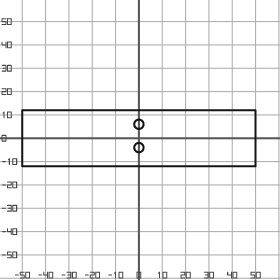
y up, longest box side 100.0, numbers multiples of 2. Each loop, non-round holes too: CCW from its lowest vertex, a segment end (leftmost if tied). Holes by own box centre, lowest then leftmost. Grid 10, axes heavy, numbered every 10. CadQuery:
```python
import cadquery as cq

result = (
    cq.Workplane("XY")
    .moveTo(-50.0, -12.0)
    .lineTo(50.0, -12.0)
    .lineTo(50.0, 12.0)
    .lineTo(-50.0, 12.0)
    .close()
    .moveTo(0.0, -4.0)
    .circle(2.0)
    .moveTo(0.0, 6.0)
    .circle(2.0)
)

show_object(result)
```